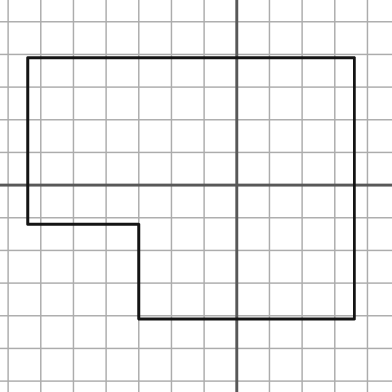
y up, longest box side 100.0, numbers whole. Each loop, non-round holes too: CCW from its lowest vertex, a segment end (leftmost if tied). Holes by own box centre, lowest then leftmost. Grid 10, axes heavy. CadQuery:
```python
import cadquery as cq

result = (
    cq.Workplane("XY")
    .moveTo(-30.0, -41.0)
    .lineTo(36.0, -41.0)
    .lineTo(36.0, 39.0)
    .lineTo(-64.0, 39.0)
    .lineTo(-64.0, -12.0)
    .lineTo(-30.0, -12.0)
    .close()
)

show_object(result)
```